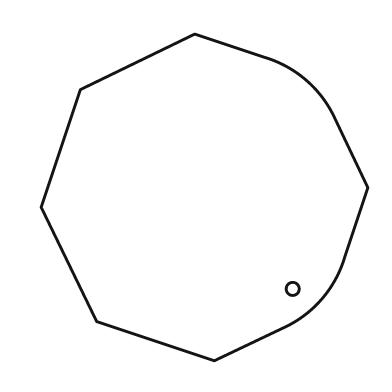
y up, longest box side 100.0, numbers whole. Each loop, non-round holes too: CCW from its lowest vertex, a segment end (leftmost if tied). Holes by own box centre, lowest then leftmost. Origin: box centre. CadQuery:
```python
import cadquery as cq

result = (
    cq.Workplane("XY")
    .moveTo(3.0, -50.0)
    .lineTo(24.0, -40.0)
    .threePointArc((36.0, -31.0), (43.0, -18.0))
    .lineTo(50.0, 3.0)
    .lineTo(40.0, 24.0)
    .threePointArc((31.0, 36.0), (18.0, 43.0))
    .lineTo(-3.0, 50.0)
    .lineTo(-38.0, 33.0)
    .lineTo(-50.0, -3.0)
    .lineTo(-33.0, -38.0)
    .close()
    .moveTo(27.0, -28.0)
    .circle(2.0)
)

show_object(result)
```